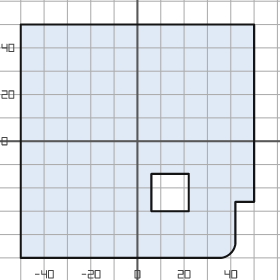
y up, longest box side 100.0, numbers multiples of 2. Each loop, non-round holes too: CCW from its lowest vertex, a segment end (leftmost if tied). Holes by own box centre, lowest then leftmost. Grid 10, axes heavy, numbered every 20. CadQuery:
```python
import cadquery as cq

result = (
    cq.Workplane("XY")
    .moveTo(-50.0, -50.0)
    .lineTo(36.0, -50.0)
    .threePointArc((40.0, -48.0), (42.0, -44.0))
    .lineTo(42.0, -26.0)
    .lineTo(50.0, -26.0)
    .lineTo(50.0, 50.0)
    .lineTo(-50.0, 50.0)
    .close()
    .moveTo(6.0, -30.0)
    .lineTo(22.0, -30.0)
    .lineTo(22.0, -14.0)
    .lineTo(6.0, -14.0)
    .close()
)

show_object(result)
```